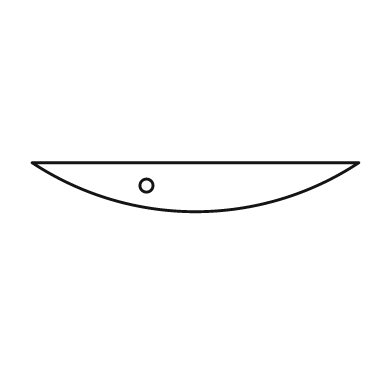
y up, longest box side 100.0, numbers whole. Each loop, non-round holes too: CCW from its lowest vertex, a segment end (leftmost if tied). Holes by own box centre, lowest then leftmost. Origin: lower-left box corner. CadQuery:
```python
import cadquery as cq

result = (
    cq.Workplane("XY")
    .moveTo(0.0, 15.0)
    .threePointArc((50.0, 0.0), (100.0, 15.0))
    .close()
    .moveTo(35.0, 8.0)
    .circle(2.0)
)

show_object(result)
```